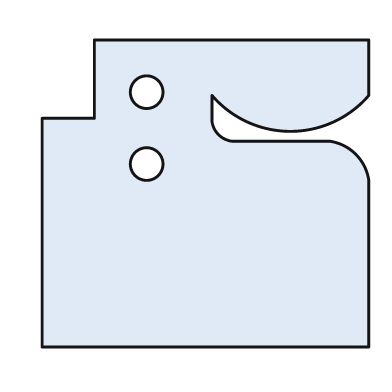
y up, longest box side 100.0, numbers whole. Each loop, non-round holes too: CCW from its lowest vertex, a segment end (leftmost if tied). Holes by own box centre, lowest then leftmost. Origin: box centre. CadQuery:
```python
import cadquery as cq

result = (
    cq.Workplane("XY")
    .moveTo(-50.0, -47.0)
    .lineTo(50.0, -47.0)
    .lineTo(50.0, 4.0)
    .threePointArc((46.0, 12.0), (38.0, 16.0))
    .lineTo(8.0, 16.0)
    .threePointArc((4.0, 18.0), (2.0, 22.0))
    .lineTo(2.0, 30.0)
    .threePointArc((26.0, 19.0), (50.0, 30.0))
    .lineTo(50.0, 47.0)
    .lineTo(-34.0, 47.0)
    .lineTo(-34.0, 23.0)
    .lineTo(-50.0, 23.0)
    .close()
    .moveTo(-18.0, 9.0)
    .circle(5.0)
    .moveTo(-18.0, 31.0)
    .circle(5.0)
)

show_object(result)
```